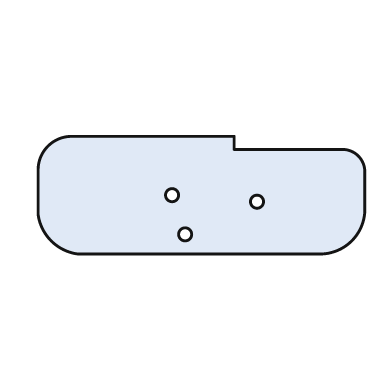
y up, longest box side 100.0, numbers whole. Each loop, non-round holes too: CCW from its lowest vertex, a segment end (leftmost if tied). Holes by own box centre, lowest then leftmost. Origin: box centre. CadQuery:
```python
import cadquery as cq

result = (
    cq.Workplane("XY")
    .moveTo(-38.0, -18.0)
    .lineTo(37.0, -18.0)
    .threePointArc((46.0, -14.0), (50.0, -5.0))
    .lineTo(50.0, 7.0)
    .threePointArc((48.0, 12.0), (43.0, 14.0))
    .lineTo(10.0, 14.0)
    .lineTo(10.0, 18.0)
    .lineTo(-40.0, 18.0)
    .threePointArc((-47.0, 15.0), (-50.0, 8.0))
    .lineTo(-50.0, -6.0)
    .threePointArc((-46.0, -14.0), (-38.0, -18.0))
    .close()
    .moveTo(-5.0, -12.0)
    .circle(2.0)
    .moveTo(17.0, -2.0)
    .circle(2.0)
    .moveTo(-9.0, 0.0)
    .circle(2.0)
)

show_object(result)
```